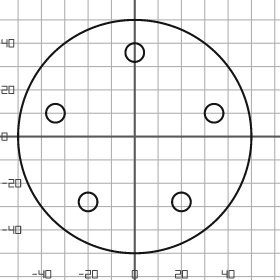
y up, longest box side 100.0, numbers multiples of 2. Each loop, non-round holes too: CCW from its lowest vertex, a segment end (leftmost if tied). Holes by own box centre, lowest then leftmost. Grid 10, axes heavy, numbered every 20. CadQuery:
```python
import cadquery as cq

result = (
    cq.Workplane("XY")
    .moveTo(0.0, 0.0)
    .circle(50.0)
    .moveTo(-20.0, -28.0)
    .circle(4.0)
    .moveTo(20.0, -28.0)
    .circle(4.0)
    .moveTo(-34.0, 10.0)
    .circle(4.0)
    .moveTo(34.0, 10.0)
    .circle(4.0)
    .moveTo(0.0, 36.0)
    .circle(4.0)
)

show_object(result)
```